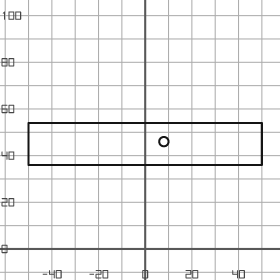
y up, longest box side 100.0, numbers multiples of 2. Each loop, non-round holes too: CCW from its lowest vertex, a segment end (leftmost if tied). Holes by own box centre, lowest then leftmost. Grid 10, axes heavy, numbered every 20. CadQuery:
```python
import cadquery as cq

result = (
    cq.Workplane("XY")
    .moveTo(-50.0, 36.0)
    .lineTo(50.0, 36.0)
    .lineTo(50.0, 54.0)
    .lineTo(-50.0, 54.0)
    .close()
    .moveTo(8.0, 46.0)
    .circle(2.0)
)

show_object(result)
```